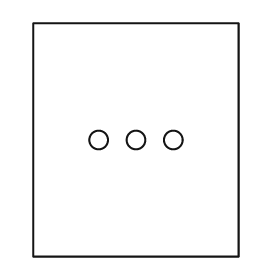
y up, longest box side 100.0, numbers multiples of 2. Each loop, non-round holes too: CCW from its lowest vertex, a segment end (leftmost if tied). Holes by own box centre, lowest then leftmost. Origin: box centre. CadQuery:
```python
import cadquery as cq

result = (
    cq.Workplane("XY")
    .moveTo(-44.0, -50.0)
    .lineTo(44.0, -50.0)
    .lineTo(44.0, 50.0)
    .lineTo(-44.0, 50.0)
    .close()
    .moveTo(-16.0, 0.0)
    .circle(4.0)
    .moveTo(0.0, 0.0)
    .circle(4.0)
    .moveTo(16.0, 0.0)
    .circle(4.0)
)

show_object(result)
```